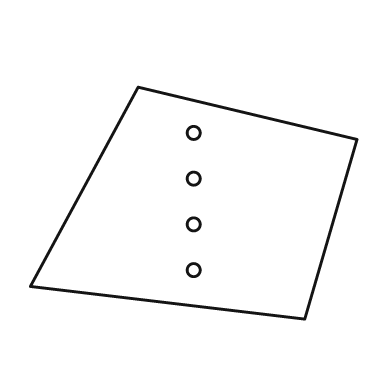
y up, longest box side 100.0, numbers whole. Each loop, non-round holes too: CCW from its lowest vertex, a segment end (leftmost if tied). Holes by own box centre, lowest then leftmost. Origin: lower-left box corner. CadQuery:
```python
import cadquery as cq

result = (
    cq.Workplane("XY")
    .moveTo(84.0, 0.0)
    .lineTo(100.0, 55.0)
    .lineTo(33.0, 71.0)
    .lineTo(0.0, 10.0)
    .close()
    .moveTo(50.0, 15.0)
    .circle(2.0)
    .moveTo(50.0, 29.0)
    .circle(2.0)
    .moveTo(50.0, 43.0)
    .circle(2.0)
    .moveTo(50.0, 57.0)
    .circle(2.0)
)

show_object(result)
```